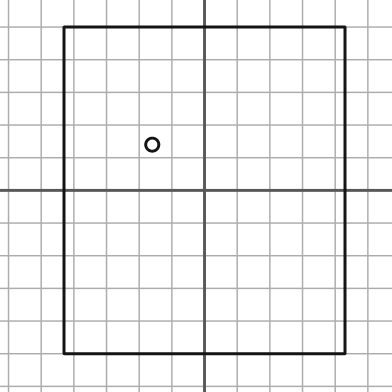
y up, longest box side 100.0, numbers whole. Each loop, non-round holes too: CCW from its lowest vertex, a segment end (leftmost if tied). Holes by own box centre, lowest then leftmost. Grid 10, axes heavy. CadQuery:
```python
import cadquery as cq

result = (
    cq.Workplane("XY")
    .moveTo(-43.0, -50.0)
    .lineTo(43.0, -50.0)
    .lineTo(43.0, 50.0)
    .lineTo(-43.0, 50.0)
    .close()
    .moveTo(-16.0, 14.0)
    .circle(2.0)
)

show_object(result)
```